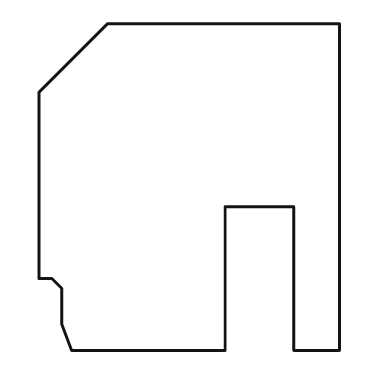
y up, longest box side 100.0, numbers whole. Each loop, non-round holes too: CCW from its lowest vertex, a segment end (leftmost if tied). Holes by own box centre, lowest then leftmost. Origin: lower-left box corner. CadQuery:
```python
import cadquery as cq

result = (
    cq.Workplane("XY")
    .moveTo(10.0, 0.0)
    .lineTo(57.0, 0.0)
    .lineTo(57.0, 44.0)
    .lineTo(78.0, 44.0)
    .lineTo(78.0, 0.0)
    .lineTo(92.0, 0.0)
    .lineTo(92.0, 100.0)
    .lineTo(21.0, 100.0)
    .lineTo(0.0, 79.0)
    .lineTo(0.0, 22.0)
    .lineTo(4.0, 22.0)
    .lineTo(7.0, 19.0)
    .lineTo(7.0, 8.0)
    .close()
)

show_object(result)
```